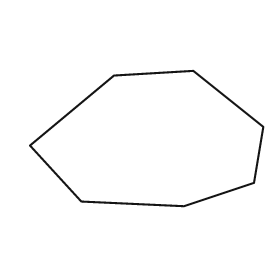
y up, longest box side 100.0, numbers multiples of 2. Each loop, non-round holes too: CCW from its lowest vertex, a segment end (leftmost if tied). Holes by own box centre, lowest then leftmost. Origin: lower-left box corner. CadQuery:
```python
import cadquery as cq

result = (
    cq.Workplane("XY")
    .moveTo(66.0, 0.0)
    .lineTo(96.0, 10.0)
    .lineTo(100.0, 34.0)
    .lineTo(70.0, 58.0)
    .lineTo(36.0, 56.0)
    .lineTo(0.0, 26.0)
    .lineTo(22.0, 2.0)
    .close()
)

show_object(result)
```